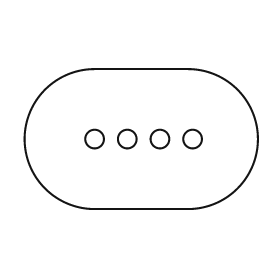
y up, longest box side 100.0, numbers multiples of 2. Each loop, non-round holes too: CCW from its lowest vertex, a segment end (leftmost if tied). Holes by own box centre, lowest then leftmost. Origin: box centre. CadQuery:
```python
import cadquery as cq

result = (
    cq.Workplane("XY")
    .moveTo(-20.0, -30.0)
    .lineTo(20.0, -30.0)
    .threePointArc((50.0, 0.0), (20.0, 30.0))
    .lineTo(-20.0, 30.0)
    .threePointArc((-50.0, 0.0), (-20.0, -30.0))
    .close()
    .moveTo(-20.0, 0.0)
    .circle(4.0)
    .moveTo(-6.0, 0.0)
    .circle(4.0)
    .moveTo(8.0, 0.0)
    .circle(4.0)
    .moveTo(22.0, 0.0)
    .circle(4.0)
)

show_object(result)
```